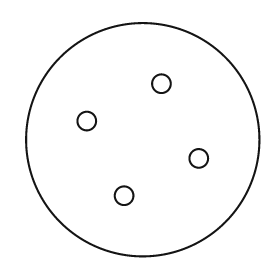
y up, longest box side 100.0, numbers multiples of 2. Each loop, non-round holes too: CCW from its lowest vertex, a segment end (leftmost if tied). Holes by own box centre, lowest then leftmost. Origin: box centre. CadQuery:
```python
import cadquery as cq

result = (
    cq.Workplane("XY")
    .moveTo(0.0, 0.0)
    .circle(50.0)
    .moveTo(-8.0, -24.0)
    .circle(4.0)
    .moveTo(24.0, -8.0)
    .circle(4.0)
    .moveTo(-24.0, 8.0)
    .circle(4.0)
    .moveTo(8.0, 24.0)
    .circle(4.0)
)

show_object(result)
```